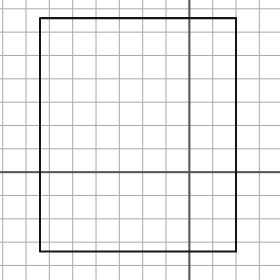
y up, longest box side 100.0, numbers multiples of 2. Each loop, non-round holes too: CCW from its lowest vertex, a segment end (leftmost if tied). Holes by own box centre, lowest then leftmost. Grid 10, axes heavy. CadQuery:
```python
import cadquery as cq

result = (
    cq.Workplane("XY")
    .moveTo(-64.0, -34.0)
    .lineTo(20.0, -34.0)
    .lineTo(20.0, 66.0)
    .lineTo(-64.0, 66.0)
    .close()
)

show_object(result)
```